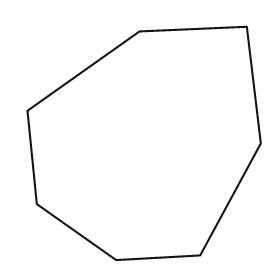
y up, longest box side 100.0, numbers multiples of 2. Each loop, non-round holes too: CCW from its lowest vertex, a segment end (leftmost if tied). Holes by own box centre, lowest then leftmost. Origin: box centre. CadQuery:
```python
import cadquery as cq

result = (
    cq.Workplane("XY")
    .moveTo(-12.0, -50.0)
    .lineTo(24.0, -48.0)
    .lineTo(50.0, 0.0)
    .lineTo(44.0, 50.0)
    .lineTo(-2.0, 48.0)
    .lineTo(-50.0, 14.0)
    .lineTo(-46.0, -26.0)
    .close()
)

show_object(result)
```